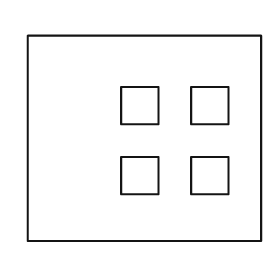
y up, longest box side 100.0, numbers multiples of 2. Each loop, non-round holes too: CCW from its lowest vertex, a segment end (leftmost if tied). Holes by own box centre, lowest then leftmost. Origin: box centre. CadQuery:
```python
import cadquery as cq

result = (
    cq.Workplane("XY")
    .moveTo(-50.0, -44.0)
    .lineTo(50.0, -44.0)
    .lineTo(50.0, 44.0)
    .lineTo(-50.0, 44.0)
    .close()
    .moveTo(-10.0, -24.0)
    .lineTo(6.0, -24.0)
    .lineTo(6.0, -8.0)
    .lineTo(-10.0, -8.0)
    .close()
    .moveTo(20.0, -24.0)
    .lineTo(36.0, -24.0)
    .lineTo(36.0, -8.0)
    .lineTo(20.0, -8.0)
    .close()
    .moveTo(-10.0, 6.0)
    .lineTo(6.0, 6.0)
    .lineTo(6.0, 22.0)
    .lineTo(-10.0, 22.0)
    .close()
    .moveTo(20.0, 6.0)
    .lineTo(36.0, 6.0)
    .lineTo(36.0, 22.0)
    .lineTo(20.0, 22.0)
    .close()
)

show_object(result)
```